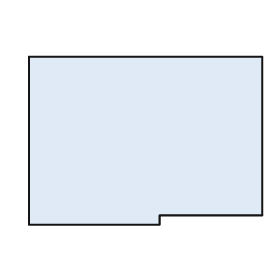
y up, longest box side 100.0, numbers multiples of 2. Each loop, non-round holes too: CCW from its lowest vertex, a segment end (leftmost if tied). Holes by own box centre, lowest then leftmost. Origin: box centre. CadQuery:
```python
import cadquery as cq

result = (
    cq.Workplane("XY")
    .moveTo(-50.0, -36.0)
    .lineTo(6.0, -36.0)
    .lineTo(6.0, -32.0)
    .lineTo(50.0, -32.0)
    .lineTo(50.0, 36.0)
    .lineTo(-50.0, 36.0)
    .close()
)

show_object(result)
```